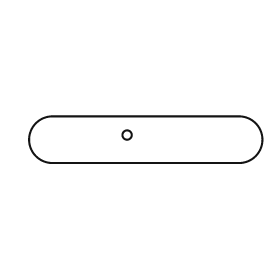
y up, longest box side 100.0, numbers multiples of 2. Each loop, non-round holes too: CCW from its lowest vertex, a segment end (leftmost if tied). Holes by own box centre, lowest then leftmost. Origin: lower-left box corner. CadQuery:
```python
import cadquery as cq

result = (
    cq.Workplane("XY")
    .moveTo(10.0, 0.0)
    .lineTo(90.0, 0.0)
    .threePointArc((100.0, 10.0), (90.0, 20.0))
    .lineTo(10.0, 20.0)
    .threePointArc((0.0, 10.0), (10.0, 0.0))
    .close()
    .moveTo(42.0, 12.0)
    .circle(2.0)
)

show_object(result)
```